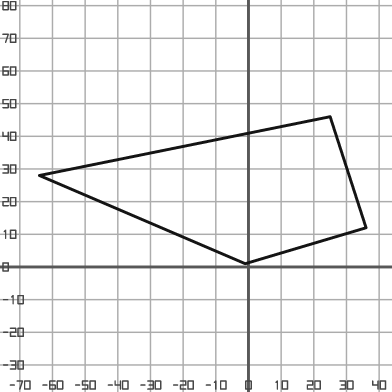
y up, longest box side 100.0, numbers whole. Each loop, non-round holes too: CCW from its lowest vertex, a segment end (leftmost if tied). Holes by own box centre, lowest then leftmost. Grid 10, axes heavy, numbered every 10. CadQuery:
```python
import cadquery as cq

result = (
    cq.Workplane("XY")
    .moveTo(-1.0, 1.0)
    .lineTo(36.0, 12.0)
    .lineTo(25.0, 46.0)
    .lineTo(-64.0, 28.0)
    .close()
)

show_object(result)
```